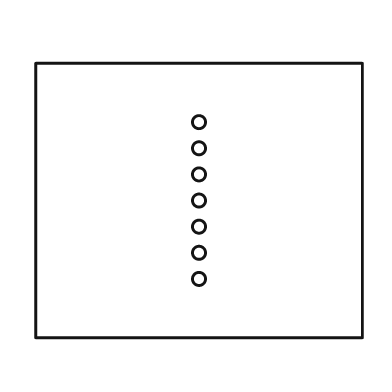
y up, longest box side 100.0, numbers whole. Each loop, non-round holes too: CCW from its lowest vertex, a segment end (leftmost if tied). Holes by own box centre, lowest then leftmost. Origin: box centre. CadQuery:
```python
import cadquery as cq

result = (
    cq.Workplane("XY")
    .moveTo(-50.0, -42.0)
    .lineTo(50.0, -42.0)
    .lineTo(50.0, 42.0)
    .lineTo(-50.0, 42.0)
    .close()
    .moveTo(0.0, -24.0)
    .circle(2.0)
    .moveTo(0.0, -16.0)
    .circle(2.0)
    .moveTo(0.0, -8.0)
    .circle(2.0)
    .moveTo(0.0, 0.0)
    .circle(2.0)
    .moveTo(0.0, 8.0)
    .circle(2.0)
    .moveTo(0.0, 16.0)
    .circle(2.0)
    .moveTo(0.0, 24.0)
    .circle(2.0)
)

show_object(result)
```